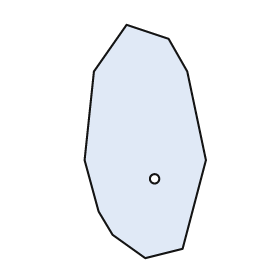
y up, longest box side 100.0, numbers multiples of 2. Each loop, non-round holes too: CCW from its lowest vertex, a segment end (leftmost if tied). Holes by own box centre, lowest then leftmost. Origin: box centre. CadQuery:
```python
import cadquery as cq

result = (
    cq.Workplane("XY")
    .moveTo(0.0, -50.0)
    .lineTo(16.0, -46.0)
    .lineTo(26.0, -8.0)
    .lineTo(18.0, 30.0)
    .lineTo(10.0, 44.0)
    .lineTo(-8.0, 50.0)
    .lineTo(-22.0, 30.0)
    .lineTo(-26.0, -8.0)
    .lineTo(-20.0, -30.0)
    .lineTo(-14.0, -40.0)
    .close()
    .moveTo(4.0, -16.0)
    .circle(2.0)
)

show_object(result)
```